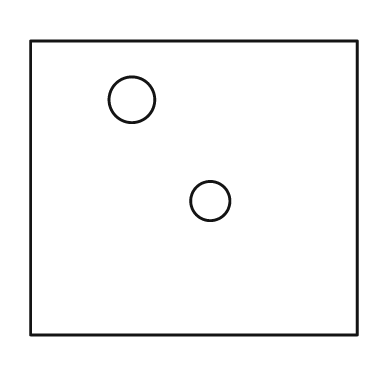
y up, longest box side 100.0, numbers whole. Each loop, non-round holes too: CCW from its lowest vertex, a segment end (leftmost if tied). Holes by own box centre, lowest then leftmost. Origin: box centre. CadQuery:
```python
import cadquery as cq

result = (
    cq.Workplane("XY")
    .moveTo(-50.0, -45.0)
    .lineTo(50.0, -45.0)
    .lineTo(50.0, 45.0)
    .lineTo(-50.0, 45.0)
    .close()
    .moveTo(5.0, -4.0)
    .circle(6.0)
    .moveTo(-19.0, 27.0)
    .circle(7.0)
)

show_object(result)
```